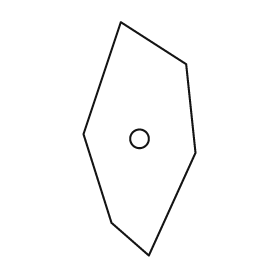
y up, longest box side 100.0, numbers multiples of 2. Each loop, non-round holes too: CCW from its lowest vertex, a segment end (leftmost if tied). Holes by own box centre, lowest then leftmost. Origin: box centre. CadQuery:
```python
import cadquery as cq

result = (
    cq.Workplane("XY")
    .moveTo(4.0, -50.0)
    .lineTo(24.0, -6.0)
    .lineTo(20.0, 32.0)
    .lineTo(-8.0, 50.0)
    .lineTo(-24.0, 2.0)
    .lineTo(-12.0, -36.0)
    .close()
    .moveTo(0.0, 0.0)
    .circle(4.0)
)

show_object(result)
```